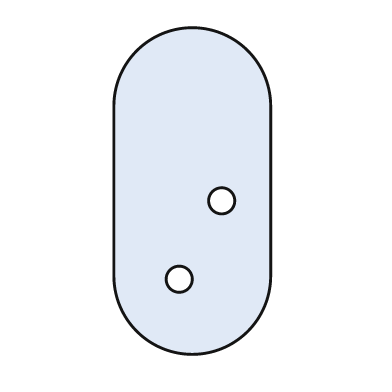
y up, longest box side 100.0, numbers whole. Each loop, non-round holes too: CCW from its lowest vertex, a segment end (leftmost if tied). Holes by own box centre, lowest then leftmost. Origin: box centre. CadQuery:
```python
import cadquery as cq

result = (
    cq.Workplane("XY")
    .moveTo(-24.0, -26.0)
    .threePointArc((0.0, -50.0), (24.0, -26.0))
    .lineTo(24.0, 26.0)
    .threePointArc((0.0, 50.0), (-24.0, 26.0))
    .close()
    .moveTo(-4.0, -27.0)
    .circle(4.0)
    .moveTo(9.0, -3.0)
    .circle(4.0)
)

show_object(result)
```